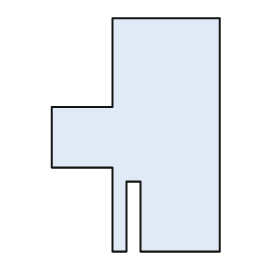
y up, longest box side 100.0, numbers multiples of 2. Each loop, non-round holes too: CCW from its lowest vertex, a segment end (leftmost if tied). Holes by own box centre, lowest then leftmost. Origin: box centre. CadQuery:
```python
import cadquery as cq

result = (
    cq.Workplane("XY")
    .moveTo(-10.0, -50.0)
    .lineTo(-4.0, -50.0)
    .lineTo(-4.0, -20.0)
    .lineTo(2.0, -20.0)
    .lineTo(2.0, -50.0)
    .lineTo(36.0, -50.0)
    .lineTo(36.0, 50.0)
    .lineTo(-10.0, 50.0)
    .lineTo(-10.0, 12.0)
    .lineTo(-36.0, 12.0)
    .lineTo(-36.0, -14.0)
    .lineTo(-10.0, -14.0)
    .close()
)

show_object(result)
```